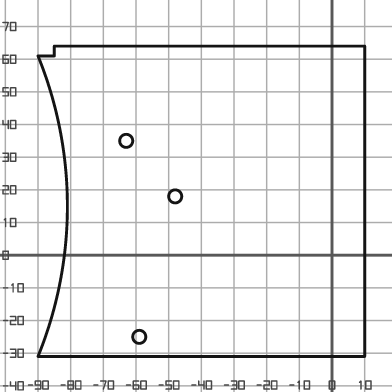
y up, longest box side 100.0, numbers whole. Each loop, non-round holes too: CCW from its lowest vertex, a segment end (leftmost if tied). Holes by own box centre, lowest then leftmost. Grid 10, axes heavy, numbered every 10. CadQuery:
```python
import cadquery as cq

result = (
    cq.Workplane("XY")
    .moveTo(-90.0, -31.0)
    .lineTo(10.0, -31.0)
    .lineTo(10.0, 64.0)
    .lineTo(-85.0, 64.0)
    .lineTo(-85.0, 61.0)
    .lineTo(-90.0, 61.0)
    .threePointArc((-81.0, 15.0), (-90.0, -31.0))
    .close()
    .moveTo(-59.0, -25.0)
    .circle(2.0)
    .moveTo(-48.0, 18.0)
    .circle(2.0)
    .moveTo(-63.0, 35.0)
    .circle(2.0)
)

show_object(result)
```